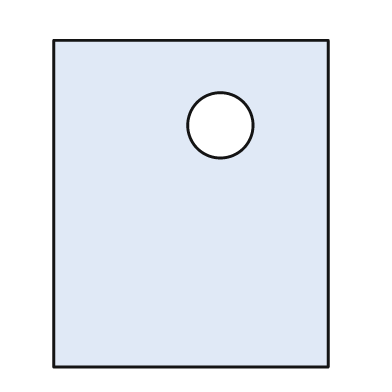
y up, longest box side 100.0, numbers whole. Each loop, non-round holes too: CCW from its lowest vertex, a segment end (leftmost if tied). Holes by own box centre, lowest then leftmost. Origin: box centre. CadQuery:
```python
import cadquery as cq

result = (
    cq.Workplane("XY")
    .moveTo(-42.0, -50.0)
    .lineTo(42.0, -50.0)
    .lineTo(42.0, 50.0)
    .lineTo(-42.0, 50.0)
    .close()
    .moveTo(9.0, 24.0)
    .circle(10.0)
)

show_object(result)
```